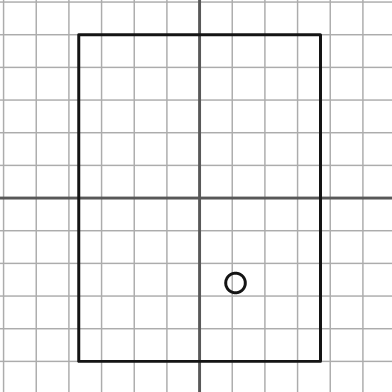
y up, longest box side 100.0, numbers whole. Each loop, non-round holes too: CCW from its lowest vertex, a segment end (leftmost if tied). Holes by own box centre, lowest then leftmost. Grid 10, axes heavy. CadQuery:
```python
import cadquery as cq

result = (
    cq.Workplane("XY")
    .moveTo(-37.0, -50.0)
    .lineTo(37.0, -50.0)
    .lineTo(37.0, 50.0)
    .lineTo(-37.0, 50.0)
    .close()
    .moveTo(11.0, -26.0)
    .circle(3.0)
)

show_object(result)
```